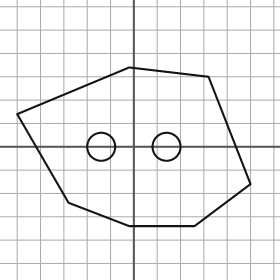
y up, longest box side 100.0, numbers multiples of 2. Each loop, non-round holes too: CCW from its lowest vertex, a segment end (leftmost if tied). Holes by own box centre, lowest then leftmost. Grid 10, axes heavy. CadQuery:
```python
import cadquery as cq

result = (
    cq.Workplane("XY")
    .moveTo(-2.0, -34.0)
    .lineTo(26.0, -34.0)
    .lineTo(50.0, -16.0)
    .lineTo(32.0, 30.0)
    .lineTo(-2.0, 34.0)
    .lineTo(-50.0, 14.0)
    .lineTo(-28.0, -24.0)
    .close()
    .moveTo(-14.0, 0.0)
    .circle(6.0)
    .moveTo(14.0, 0.0)
    .circle(6.0)
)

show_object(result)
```